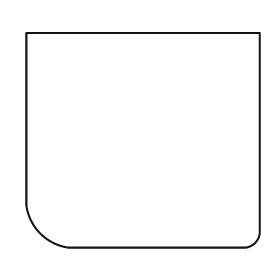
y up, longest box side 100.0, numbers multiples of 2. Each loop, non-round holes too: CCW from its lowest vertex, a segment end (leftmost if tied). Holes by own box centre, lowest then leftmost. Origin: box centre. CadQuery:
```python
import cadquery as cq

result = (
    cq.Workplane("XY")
    .moveTo(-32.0, -46.0)
    .lineTo(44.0, -46.0)
    .threePointArc((48.0, -44.0), (50.0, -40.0))
    .lineTo(50.0, 46.0)
    .lineTo(-50.0, 46.0)
    .lineTo(-50.0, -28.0)
    .threePointArc((-44.0, -40.0), (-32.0, -46.0))
    .close()
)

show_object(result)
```